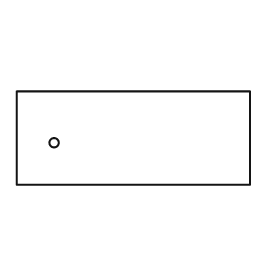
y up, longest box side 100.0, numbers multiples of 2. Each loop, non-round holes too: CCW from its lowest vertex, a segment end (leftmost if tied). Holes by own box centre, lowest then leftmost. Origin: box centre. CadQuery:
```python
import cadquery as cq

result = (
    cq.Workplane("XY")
    .moveTo(-50.0, -20.0)
    .lineTo(50.0, -20.0)
    .lineTo(50.0, 20.0)
    .lineTo(-50.0, 20.0)
    .close()
    .moveTo(-34.0, -2.0)
    .circle(2.0)
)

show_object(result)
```